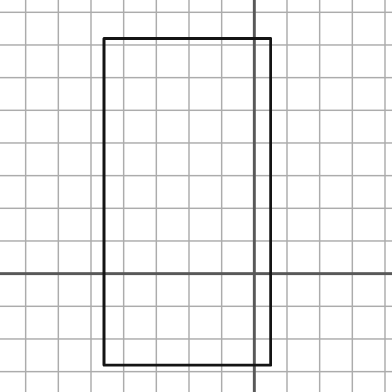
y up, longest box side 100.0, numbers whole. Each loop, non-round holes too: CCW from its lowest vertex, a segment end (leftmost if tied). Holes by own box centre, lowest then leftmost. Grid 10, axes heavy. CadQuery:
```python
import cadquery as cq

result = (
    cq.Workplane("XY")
    .moveTo(-46.0, -28.0)
    .lineTo(5.0, -28.0)
    .lineTo(5.0, 72.0)
    .lineTo(-46.0, 72.0)
    .close()
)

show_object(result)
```